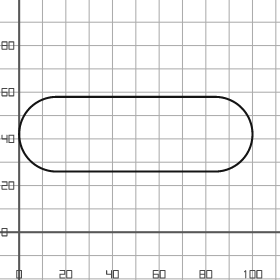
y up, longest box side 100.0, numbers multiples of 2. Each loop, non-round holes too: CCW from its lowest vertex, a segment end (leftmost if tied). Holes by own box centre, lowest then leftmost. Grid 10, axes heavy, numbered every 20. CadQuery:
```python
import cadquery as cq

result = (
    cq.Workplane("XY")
    .moveTo(16.0, 26.0)
    .lineTo(84.0, 26.0)
    .threePointArc((100.0, 42.0), (84.0, 58.0))
    .lineTo(16.0, 58.0)
    .threePointArc((0.0, 42.0), (16.0, 26.0))
    .close()
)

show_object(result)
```